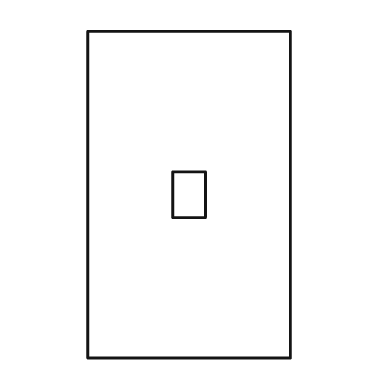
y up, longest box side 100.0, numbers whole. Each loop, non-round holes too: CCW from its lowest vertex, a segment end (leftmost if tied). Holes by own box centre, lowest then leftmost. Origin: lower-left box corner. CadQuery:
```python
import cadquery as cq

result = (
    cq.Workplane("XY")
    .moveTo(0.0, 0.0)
    .lineTo(62.0, 0.0)
    .lineTo(62.0, 100.0)
    .lineTo(0.0, 100.0)
    .close()
    .moveTo(26.0, 43.0)
    .lineTo(36.0, 43.0)
    .lineTo(36.0, 57.0)
    .lineTo(26.0, 57.0)
    .close()
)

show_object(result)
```